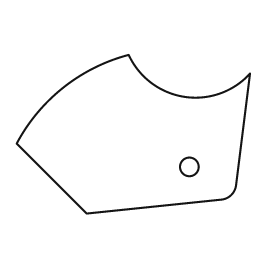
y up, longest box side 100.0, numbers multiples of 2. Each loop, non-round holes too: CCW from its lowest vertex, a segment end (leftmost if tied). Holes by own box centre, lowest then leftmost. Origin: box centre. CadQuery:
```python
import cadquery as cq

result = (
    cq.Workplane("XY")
    .moveTo(-20.0, -34.0)
    .lineTo(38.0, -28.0)
    .threePointArc((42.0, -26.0), (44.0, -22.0))
    .lineTo(50.0, 26.0)
    .threePointArc((22.0, 16.0), (-2.0, 34.0))
    .threePointArc((-30.0, 20.0), (-50.0, -4.0))
    .close()
    .moveTo(24.0, -14.0)
    .circle(4.0)
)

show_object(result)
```